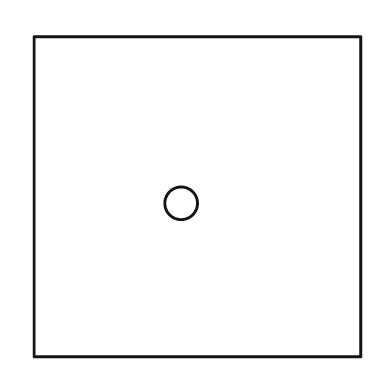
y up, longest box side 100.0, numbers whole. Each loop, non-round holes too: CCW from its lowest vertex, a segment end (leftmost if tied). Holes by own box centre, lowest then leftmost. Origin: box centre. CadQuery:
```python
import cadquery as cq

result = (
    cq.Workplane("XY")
    .moveTo(-50.0, -49.0)
    .lineTo(50.0, -49.0)
    .lineTo(50.0, 49.0)
    .lineTo(-50.0, 49.0)
    .close()
    .moveTo(-5.0, -2.0)
    .circle(5.0)
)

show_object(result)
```